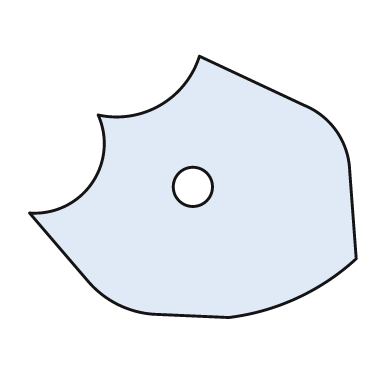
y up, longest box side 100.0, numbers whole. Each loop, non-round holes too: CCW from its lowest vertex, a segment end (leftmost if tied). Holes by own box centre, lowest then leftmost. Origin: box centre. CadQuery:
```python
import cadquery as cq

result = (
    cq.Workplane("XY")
    .moveTo(11.0, -40.0)
    .threePointArc((32.0, -34.0), (50.0, -22.0))
    .lineTo(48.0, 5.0)
    .threePointArc((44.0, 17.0), (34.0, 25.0))
    .lineTo(2.0, 40.0)
    .threePointArc((-10.0, 25.0), (-29.0, 22.0))
    .threePointArc((-31.0, 1.0), (-50.0, -8.0))
    .lineTo(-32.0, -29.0)
    .threePointArc((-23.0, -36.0), (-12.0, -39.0))
    .close()
    .moveTo(0.0, 0.0)
    .circle(6.0)
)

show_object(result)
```